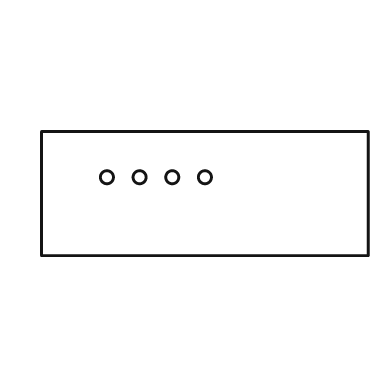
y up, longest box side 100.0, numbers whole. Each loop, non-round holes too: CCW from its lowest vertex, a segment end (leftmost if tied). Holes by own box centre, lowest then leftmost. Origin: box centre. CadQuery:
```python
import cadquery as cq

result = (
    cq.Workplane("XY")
    .moveTo(-50.0, -19.0)
    .lineTo(50.0, -19.0)
    .lineTo(50.0, 19.0)
    .lineTo(-50.0, 19.0)
    .close()
    .moveTo(-30.0, 5.0)
    .circle(2.0)
    .moveTo(-20.0, 5.0)
    .circle(2.0)
    .moveTo(-10.0, 5.0)
    .circle(2.0)
    .moveTo(0.0, 5.0)
    .circle(2.0)
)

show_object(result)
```